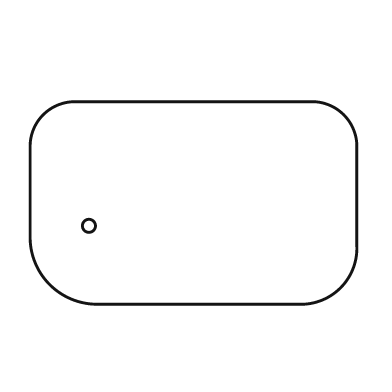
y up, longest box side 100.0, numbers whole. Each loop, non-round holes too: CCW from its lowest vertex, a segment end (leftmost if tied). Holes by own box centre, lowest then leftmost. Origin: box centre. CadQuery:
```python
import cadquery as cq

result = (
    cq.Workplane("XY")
    .moveTo(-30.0, -31.0)
    .lineTo(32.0, -31.0)
    .threePointArc((45.0, -26.0), (50.0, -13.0))
    .lineTo(50.0, 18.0)
    .threePointArc((46.0, 27.0), (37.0, 31.0))
    .lineTo(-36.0, 31.0)
    .threePointArc((-46.0, 27.0), (-50.0, 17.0))
    .lineTo(-50.0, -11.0)
    .threePointArc((-44.0, -25.0), (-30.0, -31.0))
    .close()
    .moveTo(-32.0, -7.0)
    .circle(2.0)
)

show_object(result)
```